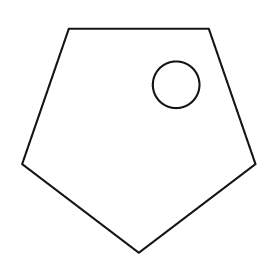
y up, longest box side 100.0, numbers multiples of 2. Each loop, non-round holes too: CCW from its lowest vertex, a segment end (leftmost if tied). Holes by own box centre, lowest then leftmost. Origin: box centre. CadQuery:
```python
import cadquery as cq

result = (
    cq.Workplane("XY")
    .moveTo(0.0, -48.0)
    .lineTo(50.0, -10.0)
    .lineTo(30.0, 48.0)
    .lineTo(-30.0, 48.0)
    .lineTo(-50.0, -10.0)
    .close()
    .moveTo(16.0, 24.0)
    .circle(10.0)
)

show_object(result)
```